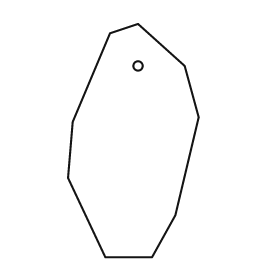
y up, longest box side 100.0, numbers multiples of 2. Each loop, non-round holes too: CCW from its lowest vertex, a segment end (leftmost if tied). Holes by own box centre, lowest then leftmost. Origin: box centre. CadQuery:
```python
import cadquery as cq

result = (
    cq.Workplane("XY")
    .moveTo(-12.0, -50.0)
    .lineTo(8.0, -50.0)
    .lineTo(18.0, -32.0)
    .lineTo(28.0, 10.0)
    .lineTo(22.0, 32.0)
    .lineTo(2.0, 50.0)
    .lineTo(-10.0, 46.0)
    .lineTo(-26.0, 8.0)
    .lineTo(-28.0, -16.0)
    .close()
    .moveTo(2.0, 32.0)
    .circle(2.0)
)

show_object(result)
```